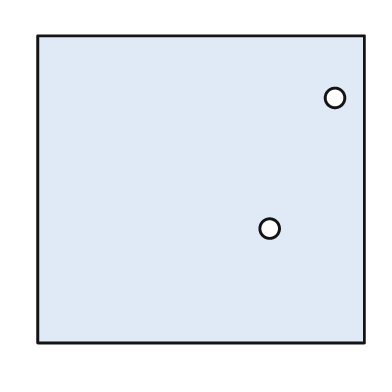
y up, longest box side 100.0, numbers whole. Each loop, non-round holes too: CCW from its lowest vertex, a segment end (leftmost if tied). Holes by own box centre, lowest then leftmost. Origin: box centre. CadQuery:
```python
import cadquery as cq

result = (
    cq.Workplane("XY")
    .moveTo(-50.0, -47.0)
    .lineTo(50.0, -47.0)
    .lineTo(50.0, 47.0)
    .lineTo(-50.0, 47.0)
    .close()
    .moveTo(21.0, -12.0)
    .circle(3.0)
    .moveTo(41.0, 28.0)
    .circle(3.0)
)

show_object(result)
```